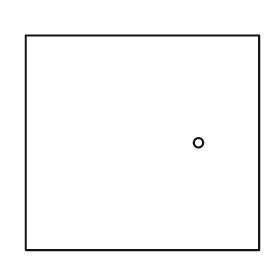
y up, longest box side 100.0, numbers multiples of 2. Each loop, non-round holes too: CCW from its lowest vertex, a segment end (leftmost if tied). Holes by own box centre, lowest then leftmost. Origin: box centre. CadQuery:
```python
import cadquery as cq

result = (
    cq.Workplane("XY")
    .moveTo(-50.0, -46.0)
    .lineTo(50.0, -46.0)
    .lineTo(50.0, 46.0)
    .lineTo(-50.0, 46.0)
    .close()
    .moveTo(24.0, 0.0)
    .circle(2.0)
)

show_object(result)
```